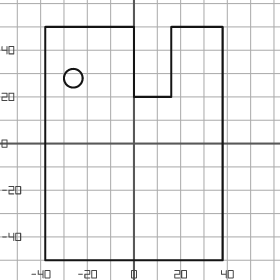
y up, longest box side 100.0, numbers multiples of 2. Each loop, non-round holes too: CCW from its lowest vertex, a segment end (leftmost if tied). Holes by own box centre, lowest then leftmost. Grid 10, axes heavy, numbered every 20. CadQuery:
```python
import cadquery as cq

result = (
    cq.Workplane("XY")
    .moveTo(-38.0, -50.0)
    .lineTo(38.0, -50.0)
    .lineTo(38.0, 50.0)
    .lineTo(16.0, 50.0)
    .lineTo(16.0, 20.0)
    .lineTo(0.0, 20.0)
    .lineTo(0.0, 50.0)
    .lineTo(-38.0, 50.0)
    .close()
    .moveTo(-26.0, 28.0)
    .circle(4.0)
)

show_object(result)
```